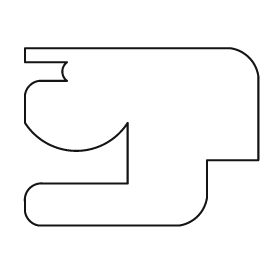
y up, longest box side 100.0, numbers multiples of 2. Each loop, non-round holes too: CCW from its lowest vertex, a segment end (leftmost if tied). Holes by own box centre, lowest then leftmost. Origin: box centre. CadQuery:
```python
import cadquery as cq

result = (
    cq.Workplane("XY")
    .moveTo(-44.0, -38.0)
    .lineTo(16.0, -38.0)
    .threePointArc((24.0, -34.0), (28.0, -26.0))
    .lineTo(28.0, -10.0)
    .lineTo(50.0, -10.0)
    .lineTo(50.0, 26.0)
    .threePointArc((46.0, 34.0), (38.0, 38.0))
    .lineTo(-50.0, 38.0)
    .lineTo(-50.0, 32.0)
    .lineTo(-32.0, 32.0)
    .threePointArc((-34.0, 28.0), (-32.0, 24.0))
    .lineTo(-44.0, 24.0)
    .threePointArc((-48.0, 22.0), (-50.0, 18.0))
    .lineTo(-50.0, 6.0)
    .threePointArc((-28.0, -6.0), (-6.0, 6.0))
    .lineTo(-6.0, -20.0)
    .lineTo(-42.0, -20.0)
    .threePointArc((-48.0, -22.0), (-50.0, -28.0))
    .lineTo(-50.0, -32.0)
    .threePointArc((-48.0, -36.0), (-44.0, -38.0))
    .close()
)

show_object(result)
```